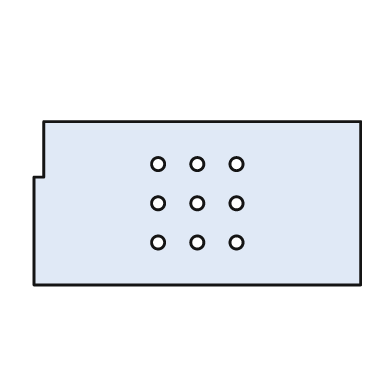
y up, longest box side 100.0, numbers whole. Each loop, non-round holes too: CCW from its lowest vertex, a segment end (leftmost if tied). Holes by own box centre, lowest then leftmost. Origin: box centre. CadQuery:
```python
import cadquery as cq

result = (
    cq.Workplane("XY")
    .moveTo(-50.0, -25.0)
    .lineTo(50.0, -25.0)
    .lineTo(50.0, 25.0)
    .lineTo(-47.0, 25.0)
    .lineTo(-47.0, 8.0)
    .lineTo(-50.0, 8.0)
    .close()
    .moveTo(-12.0, -12.0)
    .circle(2.0)
    .moveTo(0.0, -12.0)
    .circle(2.0)
    .moveTo(12.0, -12.0)
    .circle(2.0)
    .moveTo(-12.0, 0.0)
    .circle(2.0)
    .moveTo(0.0, 0.0)
    .circle(2.0)
    .moveTo(12.0, 0.0)
    .circle(2.0)
    .moveTo(-12.0, 12.0)
    .circle(2.0)
    .moveTo(0.0, 12.0)
    .circle(2.0)
    .moveTo(12.0, 12.0)
    .circle(2.0)
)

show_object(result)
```